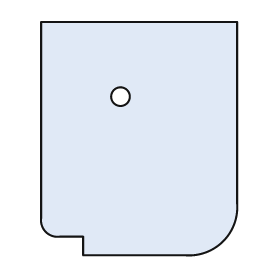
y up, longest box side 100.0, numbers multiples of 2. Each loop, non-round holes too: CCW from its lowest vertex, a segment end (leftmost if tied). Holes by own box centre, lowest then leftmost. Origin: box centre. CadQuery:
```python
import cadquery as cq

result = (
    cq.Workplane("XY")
    .moveTo(-24.0, -50.0)
    .lineTo(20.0, -50.0)
    .threePointArc((36.0, -44.0), (42.0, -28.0))
    .lineTo(42.0, 50.0)
    .lineTo(-42.0, 50.0)
    .lineTo(-42.0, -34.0)
    .threePointArc((-40.0, -40.0), (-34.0, -42.0))
    .lineTo(-24.0, -42.0)
    .close()
    .moveTo(-8.0, 18.0)
    .circle(4.0)
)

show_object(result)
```